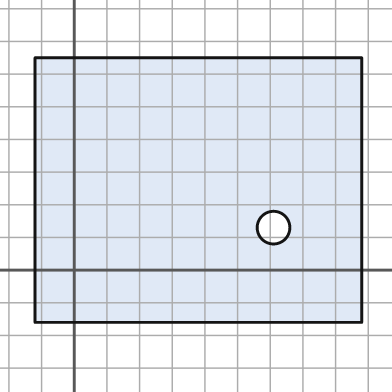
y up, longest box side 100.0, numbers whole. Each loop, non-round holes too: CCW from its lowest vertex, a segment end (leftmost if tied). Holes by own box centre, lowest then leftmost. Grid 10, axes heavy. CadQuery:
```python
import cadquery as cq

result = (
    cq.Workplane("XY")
    .moveTo(-12.0, -16.0)
    .lineTo(88.0, -16.0)
    .lineTo(88.0, 65.0)
    .lineTo(-12.0, 65.0)
    .close()
    .moveTo(61.0, 13.0)
    .circle(5.0)
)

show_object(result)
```